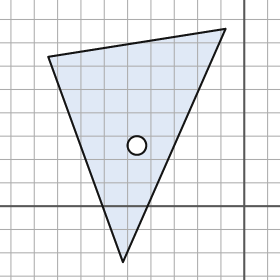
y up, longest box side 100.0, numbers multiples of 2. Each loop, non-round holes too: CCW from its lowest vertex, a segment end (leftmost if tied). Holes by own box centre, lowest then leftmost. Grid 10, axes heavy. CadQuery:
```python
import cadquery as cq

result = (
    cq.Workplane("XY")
    .moveTo(-52.0, -24.0)
    .lineTo(-8.0, 76.0)
    .lineTo(-84.0, 64.0)
    .close()
    .moveTo(-46.0, 26.0)
    .circle(4.0)
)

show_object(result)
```